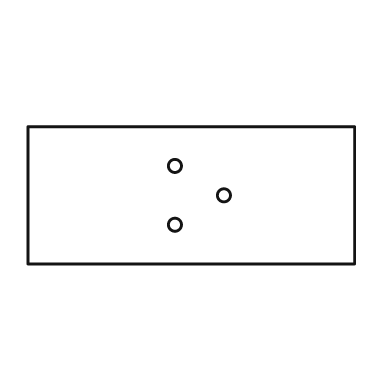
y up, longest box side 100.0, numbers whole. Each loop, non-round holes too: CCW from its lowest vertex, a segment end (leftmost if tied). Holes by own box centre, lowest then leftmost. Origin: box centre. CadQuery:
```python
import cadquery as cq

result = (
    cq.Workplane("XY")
    .moveTo(-50.0, -21.0)
    .lineTo(50.0, -21.0)
    .lineTo(50.0, 21.0)
    .lineTo(-50.0, 21.0)
    .close()
    .moveTo(-5.0, -9.0)
    .circle(2.0)
    .moveTo(10.0, 0.0)
    .circle(2.0)
    .moveTo(-5.0, 9.0)
    .circle(2.0)
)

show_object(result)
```